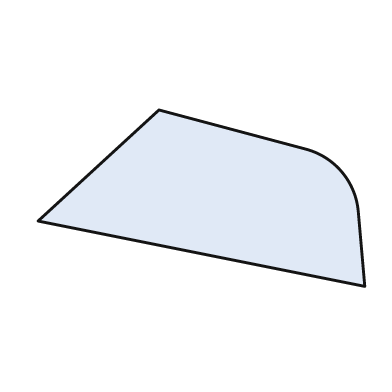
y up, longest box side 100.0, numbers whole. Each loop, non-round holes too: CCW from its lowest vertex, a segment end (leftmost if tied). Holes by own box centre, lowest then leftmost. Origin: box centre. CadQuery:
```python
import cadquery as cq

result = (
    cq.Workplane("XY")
    .moveTo(50.0, -27.0)
    .lineTo(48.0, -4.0)
    .threePointArc((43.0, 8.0), (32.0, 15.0))
    .lineTo(-13.0, 27.0)
    .lineTo(-50.0, -7.0)
    .close()
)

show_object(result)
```